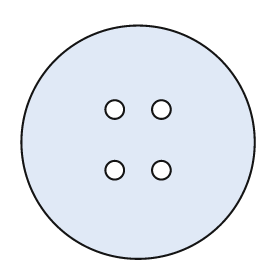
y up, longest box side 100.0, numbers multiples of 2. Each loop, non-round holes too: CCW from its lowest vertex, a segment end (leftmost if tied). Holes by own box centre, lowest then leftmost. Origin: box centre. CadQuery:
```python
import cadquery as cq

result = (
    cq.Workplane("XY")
    .moveTo(0.0, 0.0)
    .circle(50.0)
    .moveTo(-10.0, -12.0)
    .circle(4.0)
    .moveTo(10.0, -12.0)
    .circle(4.0)
    .moveTo(-10.0, 14.0)
    .circle(4.0)
    .moveTo(10.0, 14.0)
    .circle(4.0)
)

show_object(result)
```